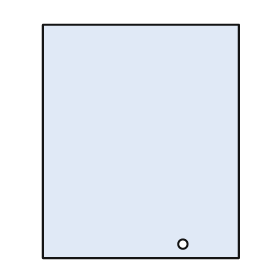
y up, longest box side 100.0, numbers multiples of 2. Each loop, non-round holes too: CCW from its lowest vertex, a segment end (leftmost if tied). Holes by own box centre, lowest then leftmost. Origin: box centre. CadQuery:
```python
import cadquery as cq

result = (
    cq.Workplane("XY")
    .moveTo(-42.0, -50.0)
    .lineTo(42.0, -50.0)
    .lineTo(42.0, 50.0)
    .lineTo(-42.0, 50.0)
    .close()
    .moveTo(18.0, -44.0)
    .circle(2.0)
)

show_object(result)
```